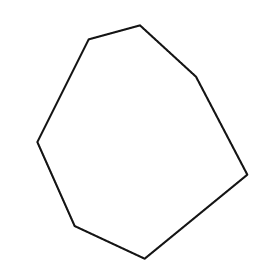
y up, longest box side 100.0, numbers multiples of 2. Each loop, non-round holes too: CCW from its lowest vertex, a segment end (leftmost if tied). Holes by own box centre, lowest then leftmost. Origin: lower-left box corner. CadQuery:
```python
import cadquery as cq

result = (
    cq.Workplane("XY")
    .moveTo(46.0, 0.0)
    .lineTo(90.0, 36.0)
    .lineTo(68.0, 78.0)
    .lineTo(44.0, 100.0)
    .lineTo(22.0, 94.0)
    .lineTo(0.0, 50.0)
    .lineTo(16.0, 14.0)
    .close()
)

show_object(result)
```